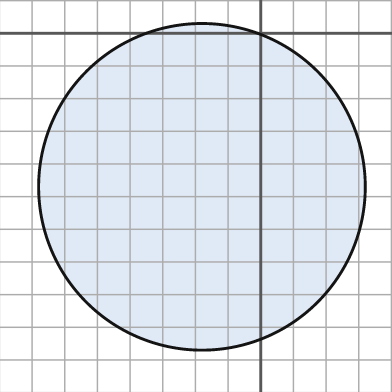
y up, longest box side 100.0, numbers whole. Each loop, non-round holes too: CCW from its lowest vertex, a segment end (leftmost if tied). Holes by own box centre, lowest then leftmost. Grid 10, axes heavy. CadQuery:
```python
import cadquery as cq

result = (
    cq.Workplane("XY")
    .moveTo(-18.0, -47.0)
    .circle(50.0)
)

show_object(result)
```